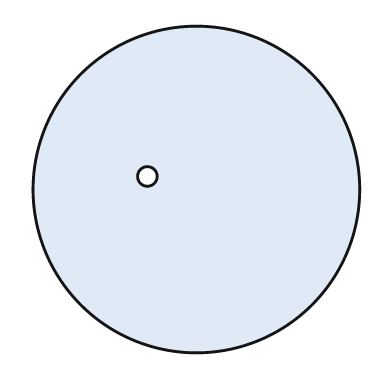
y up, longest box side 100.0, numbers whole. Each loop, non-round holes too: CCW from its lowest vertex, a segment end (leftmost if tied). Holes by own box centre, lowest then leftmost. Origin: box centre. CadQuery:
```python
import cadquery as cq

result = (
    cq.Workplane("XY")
    .moveTo(0.0, 0.0)
    .circle(50.0)
    .moveTo(-15.0, 4.0)
    .circle(3.0)
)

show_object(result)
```